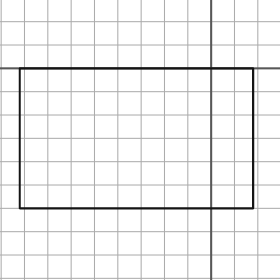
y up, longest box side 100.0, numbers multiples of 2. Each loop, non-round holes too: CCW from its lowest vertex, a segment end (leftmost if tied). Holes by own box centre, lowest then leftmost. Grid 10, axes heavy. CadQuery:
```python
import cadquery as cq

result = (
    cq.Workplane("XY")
    .moveTo(-82.0, -60.0)
    .lineTo(18.0, -60.0)
    .lineTo(18.0, 0.0)
    .lineTo(-82.0, 0.0)
    .close()
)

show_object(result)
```